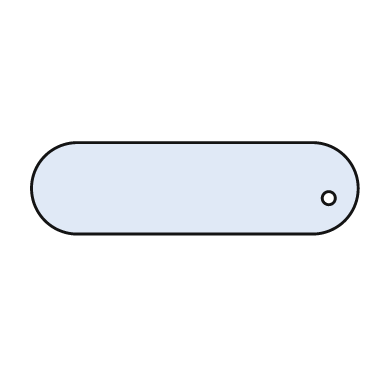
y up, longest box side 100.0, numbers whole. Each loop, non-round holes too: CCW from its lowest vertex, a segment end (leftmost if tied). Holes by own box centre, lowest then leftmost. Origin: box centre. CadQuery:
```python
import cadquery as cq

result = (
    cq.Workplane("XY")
    .moveTo(-36.0, -14.0)
    .lineTo(36.0, -14.0)
    .threePointArc((50.0, 0.0), (36.0, 14.0))
    .lineTo(-36.0, 14.0)
    .threePointArc((-50.0, 0.0), (-36.0, -14.0))
    .close()
    .moveTo(41.0, -3.0)
    .circle(2.0)
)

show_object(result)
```